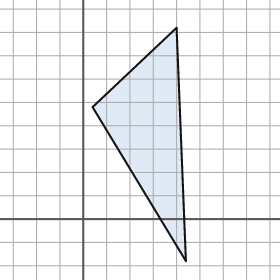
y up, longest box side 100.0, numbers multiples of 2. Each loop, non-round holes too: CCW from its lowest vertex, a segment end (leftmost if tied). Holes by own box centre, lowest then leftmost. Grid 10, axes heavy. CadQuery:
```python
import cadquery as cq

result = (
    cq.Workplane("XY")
    .moveTo(44.0, -18.0)
    .lineTo(40.0, 82.0)
    .lineTo(4.0, 48.0)
    .close()
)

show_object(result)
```